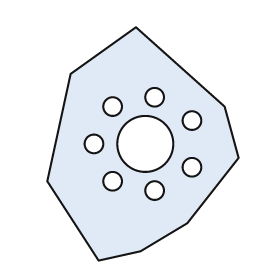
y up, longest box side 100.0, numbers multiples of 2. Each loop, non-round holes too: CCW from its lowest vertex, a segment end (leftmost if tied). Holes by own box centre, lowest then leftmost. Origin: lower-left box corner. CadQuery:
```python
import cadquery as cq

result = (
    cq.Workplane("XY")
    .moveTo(22.0, 0.0)
    .lineTo(40.0, 4.0)
    .lineTo(60.0, 16.0)
    .lineTo(82.0, 44.0)
    .lineTo(76.0, 66.0)
    .lineTo(38.0, 100.0)
    .lineTo(10.0, 80.0)
    .lineTo(0.0, 34.0)
    .close()
    .moveTo(46.0, 30.0)
    .circle(4.0)
    .moveTo(28.0, 34.0)
    .circle(4.0)
    .moveTo(62.0, 40.0)
    .circle(4.0)
    .moveTo(20.0, 50.0)
    .circle(4.0)
    .moveTo(42.0, 50.0)
    .circle(12.0)
    .moveTo(62.0, 60.0)
    .circle(4.0)
    .moveTo(28.0, 66.0)
    .circle(4.0)
    .moveTo(46.0, 70.0)
    .circle(4.0)
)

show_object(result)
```